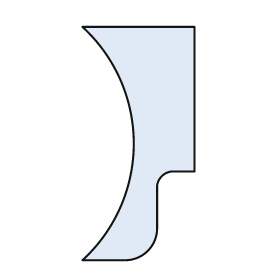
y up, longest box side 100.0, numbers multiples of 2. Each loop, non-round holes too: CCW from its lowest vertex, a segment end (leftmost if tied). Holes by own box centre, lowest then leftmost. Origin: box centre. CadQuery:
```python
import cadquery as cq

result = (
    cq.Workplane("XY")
    .moveTo(-24.0, -50.0)
    .lineTo(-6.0, -50.0)
    .threePointArc((4.0, -46.0), (8.0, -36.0))
    .lineTo(8.0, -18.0)
    .threePointArc((10.0, -14.0), (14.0, -12.0))
    .lineTo(24.0, -12.0)
    .lineTo(24.0, 50.0)
    .lineTo(-24.0, 50.0)
    .threePointArc((-2.0, 0.0), (-24.0, -50.0))
    .close()
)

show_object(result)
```